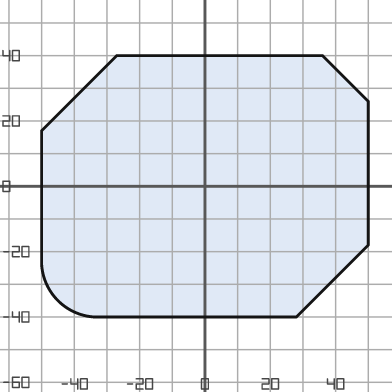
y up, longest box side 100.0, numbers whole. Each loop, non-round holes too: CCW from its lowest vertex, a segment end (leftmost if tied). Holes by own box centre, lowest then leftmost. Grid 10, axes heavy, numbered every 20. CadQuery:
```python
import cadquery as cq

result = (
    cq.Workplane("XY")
    .moveTo(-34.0, -40.0)
    .lineTo(28.0, -40.0)
    .lineTo(50.0, -18.0)
    .lineTo(50.0, 26.0)
    .lineTo(36.0, 40.0)
    .lineTo(-27.0, 40.0)
    .lineTo(-50.0, 17.0)
    .lineTo(-50.0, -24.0)
    .threePointArc((-45.0, -35.0), (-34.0, -40.0))
    .close()
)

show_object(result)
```